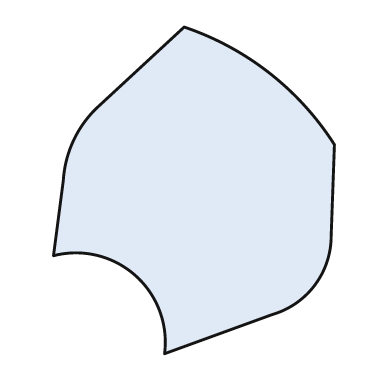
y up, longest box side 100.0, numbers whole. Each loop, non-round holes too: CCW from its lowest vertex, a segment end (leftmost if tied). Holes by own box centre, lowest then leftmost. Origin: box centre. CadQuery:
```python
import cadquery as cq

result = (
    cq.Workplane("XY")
    .moveTo(-9.0, -50.0)
    .lineTo(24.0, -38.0)
    .threePointArc((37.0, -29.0), (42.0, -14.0))
    .lineTo(43.0, 14.0)
    .threePointArc((23.0, 36.0), (-3.0, 50.0))
    .lineTo(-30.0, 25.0)
    .threePointArc((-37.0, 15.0), (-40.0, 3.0))
    .lineTo(-43.0, -20.0)
    .threePointArc((-18.0, -26.0), (-9.0, -50.0))
    .close()
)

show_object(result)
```